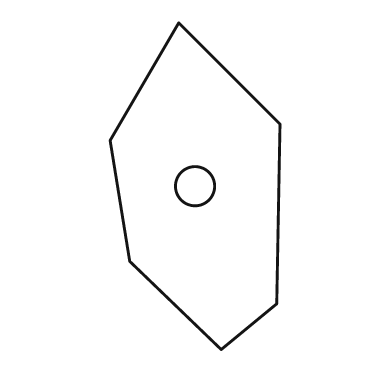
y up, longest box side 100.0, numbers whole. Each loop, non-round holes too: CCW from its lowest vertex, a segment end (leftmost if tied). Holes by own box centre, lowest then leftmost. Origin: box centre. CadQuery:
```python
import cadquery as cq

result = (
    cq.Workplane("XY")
    .moveTo(8.0, -50.0)
    .lineTo(25.0, -36.0)
    .lineTo(26.0, 19.0)
    .lineTo(-5.0, 50.0)
    .lineTo(-26.0, 14.0)
    .lineTo(-20.0, -23.0)
    .close()
    .moveTo(0.0, 0.0)
    .circle(6.0)
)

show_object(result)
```